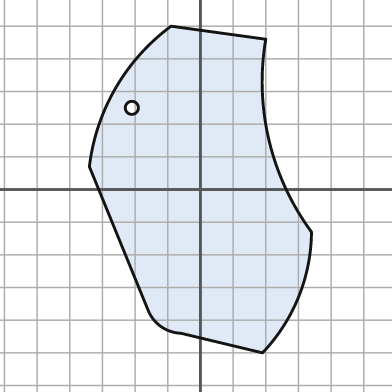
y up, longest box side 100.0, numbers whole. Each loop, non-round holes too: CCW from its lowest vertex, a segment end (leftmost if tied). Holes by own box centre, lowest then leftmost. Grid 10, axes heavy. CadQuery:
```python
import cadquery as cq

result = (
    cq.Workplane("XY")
    .moveTo(19.0, -50.0)
    .threePointArc((30.0, -33.0), (34.0, -13.0))
    .threePointArc((21.0, 15.0), (20.0, 46.0))
    .lineTo(-9.0, 50.0)
    .threePointArc((-26.0, 31.0), (-34.0, 7.0))
    .lineTo(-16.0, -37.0)
    .threePointArc((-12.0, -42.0), (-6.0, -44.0))
    .close()
    .moveTo(-21.0, 25.0)
    .circle(2.0)
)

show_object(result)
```